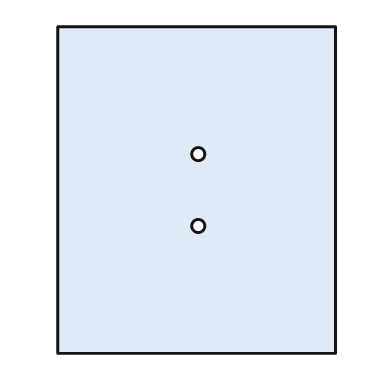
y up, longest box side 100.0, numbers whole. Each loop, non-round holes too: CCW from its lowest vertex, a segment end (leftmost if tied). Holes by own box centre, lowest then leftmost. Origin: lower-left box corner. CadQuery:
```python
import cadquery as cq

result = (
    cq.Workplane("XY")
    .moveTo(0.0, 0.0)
    .lineTo(85.0, 0.0)
    .lineTo(85.0, 100.0)
    .lineTo(0.0, 100.0)
    .close()
    .moveTo(43.0, 39.0)
    .circle(2.0)
    .moveTo(43.0, 61.0)
    .circle(2.0)
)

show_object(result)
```